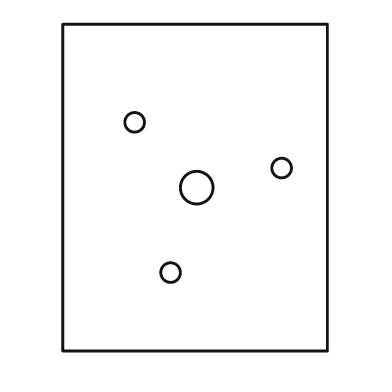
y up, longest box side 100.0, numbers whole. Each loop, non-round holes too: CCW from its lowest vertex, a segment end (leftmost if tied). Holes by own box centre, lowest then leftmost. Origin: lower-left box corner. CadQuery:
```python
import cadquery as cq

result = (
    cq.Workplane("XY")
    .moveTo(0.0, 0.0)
    .lineTo(81.0, 0.0)
    .lineTo(81.0, 100.0)
    .lineTo(0.0, 100.0)
    .close()
    .moveTo(33.0, 24.0)
    .circle(3.0)
    .moveTo(41.0, 50.0)
    .circle(5.0)
    .moveTo(67.0, 56.0)
    .circle(3.0)
    .moveTo(22.0, 70.0)
    .circle(3.0)
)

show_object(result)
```